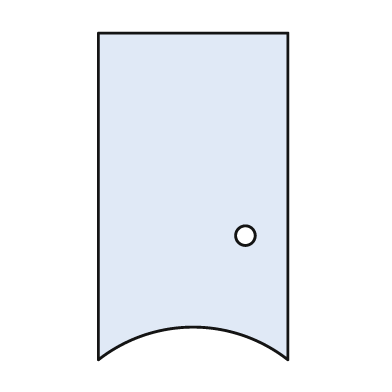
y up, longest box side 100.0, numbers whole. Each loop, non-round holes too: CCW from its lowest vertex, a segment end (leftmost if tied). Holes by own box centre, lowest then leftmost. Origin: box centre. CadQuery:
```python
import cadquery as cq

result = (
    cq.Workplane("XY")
    .moveTo(-29.0, -50.0)
    .threePointArc((0.0, -40.0), (29.0, -50.0))
    .lineTo(29.0, 50.0)
    .lineTo(-29.0, 50.0)
    .close()
    .moveTo(16.0, -12.0)
    .circle(3.0)
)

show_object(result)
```